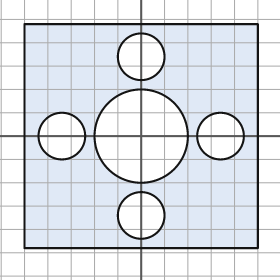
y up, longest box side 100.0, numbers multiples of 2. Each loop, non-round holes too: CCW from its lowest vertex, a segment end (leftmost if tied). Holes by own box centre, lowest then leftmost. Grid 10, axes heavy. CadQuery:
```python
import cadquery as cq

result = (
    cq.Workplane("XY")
    .moveTo(-50.0, -48.0)
    .lineTo(50.0, -48.0)
    .lineTo(50.0, 48.0)
    .lineTo(-50.0, 48.0)
    .close()
    .moveTo(0.0, -34.0)
    .circle(10.0)
    .moveTo(-34.0, 0.0)
    .circle(10.0)
    .moveTo(0.0, 0.0)
    .circle(20.0)
    .moveTo(34.0, 0.0)
    .circle(10.0)
    .moveTo(0.0, 34.0)
    .circle(10.0)
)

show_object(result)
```